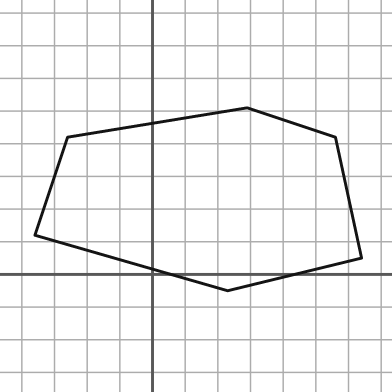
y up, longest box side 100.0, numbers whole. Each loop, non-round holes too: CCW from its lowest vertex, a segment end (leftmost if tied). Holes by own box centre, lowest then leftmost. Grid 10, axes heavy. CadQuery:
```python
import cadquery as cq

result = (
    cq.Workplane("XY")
    .moveTo(23.0, -5.0)
    .lineTo(64.0, 5.0)
    .lineTo(56.0, 42.0)
    .lineTo(29.0, 51.0)
    .lineTo(-26.0, 42.0)
    .lineTo(-36.0, 12.0)
    .close()
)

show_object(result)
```